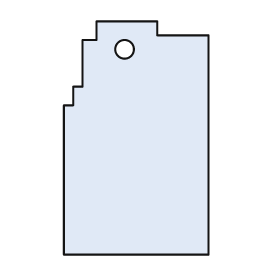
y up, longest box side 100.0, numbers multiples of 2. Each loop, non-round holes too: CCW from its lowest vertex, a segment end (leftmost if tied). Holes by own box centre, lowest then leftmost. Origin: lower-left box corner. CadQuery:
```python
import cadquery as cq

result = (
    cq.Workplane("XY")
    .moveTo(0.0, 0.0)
    .lineTo(62.0, 0.0)
    .lineTo(62.0, 94.0)
    .lineTo(40.0, 94.0)
    .lineTo(40.0, 100.0)
    .lineTo(14.0, 100.0)
    .lineTo(14.0, 92.0)
    .lineTo(8.0, 92.0)
    .lineTo(8.0, 72.0)
    .lineTo(4.0, 72.0)
    .lineTo(4.0, 64.0)
    .lineTo(0.0, 64.0)
    .close()
    .moveTo(26.0, 88.0)
    .circle(4.0)
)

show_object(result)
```